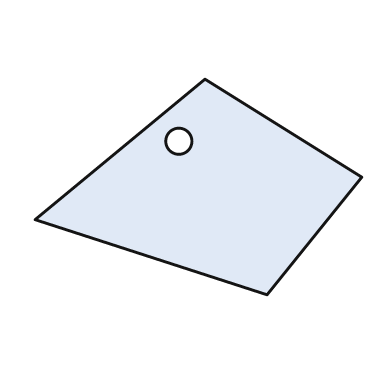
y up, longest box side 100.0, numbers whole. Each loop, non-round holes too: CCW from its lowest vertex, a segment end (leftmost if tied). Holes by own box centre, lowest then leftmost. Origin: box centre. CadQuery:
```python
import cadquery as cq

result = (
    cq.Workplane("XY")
    .moveTo(21.0, -33.0)
    .lineTo(50.0, 3.0)
    .lineTo(2.0, 33.0)
    .lineTo(-50.0, -10.0)
    .close()
    .moveTo(-6.0, 14.0)
    .circle(4.0)
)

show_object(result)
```